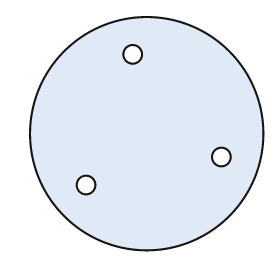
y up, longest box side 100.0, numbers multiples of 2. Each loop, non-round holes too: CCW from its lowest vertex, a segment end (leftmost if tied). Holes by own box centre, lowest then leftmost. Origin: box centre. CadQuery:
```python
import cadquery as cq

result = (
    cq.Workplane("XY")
    .moveTo(0.0, 0.0)
    .circle(50.0)
    .moveTo(-26.0, -22.0)
    .circle(4.0)
    .moveTo(32.0, -10.0)
    .circle(4.0)
    .moveTo(-6.0, 34.0)
    .circle(4.0)
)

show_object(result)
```